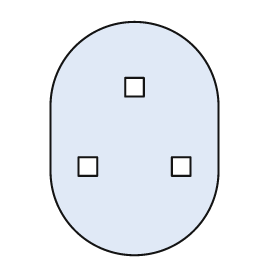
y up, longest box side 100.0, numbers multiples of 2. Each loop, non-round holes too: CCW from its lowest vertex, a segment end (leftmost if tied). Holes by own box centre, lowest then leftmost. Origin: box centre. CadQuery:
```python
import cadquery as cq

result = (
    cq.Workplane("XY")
    .moveTo(-36.0, -14.0)
    .threePointArc((0.0, -50.0), (36.0, -14.0))
    .lineTo(36.0, 14.0)
    .threePointArc((0.0, 50.0), (-36.0, 14.0))
    .close()
    .moveTo(-24.0, -16.0)
    .lineTo(-16.0, -16.0)
    .lineTo(-16.0, -8.0)
    .lineTo(-24.0, -8.0)
    .close()
    .moveTo(16.0, -16.0)
    .lineTo(24.0, -16.0)
    .lineTo(24.0, -8.0)
    .lineTo(16.0, -8.0)
    .close()
    .moveTo(-4.0, 18.0)
    .lineTo(4.0, 18.0)
    .lineTo(4.0, 26.0)
    .lineTo(-4.0, 26.0)
    .close()
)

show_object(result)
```